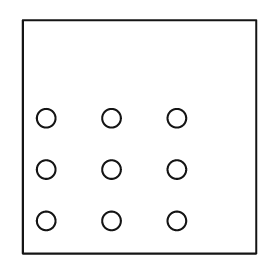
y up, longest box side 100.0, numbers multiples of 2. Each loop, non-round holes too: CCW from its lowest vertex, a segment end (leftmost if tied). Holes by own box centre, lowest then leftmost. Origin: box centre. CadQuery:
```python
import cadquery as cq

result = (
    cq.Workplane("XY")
    .moveTo(-50.0, -50.0)
    .lineTo(50.0, -50.0)
    .lineTo(50.0, 50.0)
    .lineTo(-50.0, 50.0)
    .close()
    .moveTo(-40.0, -36.0)
    .circle(4.0)
    .moveTo(-12.0, -36.0)
    .circle(4.0)
    .moveTo(16.0, -36.0)
    .circle(4.0)
    .moveTo(-40.0, -14.0)
    .circle(4.0)
    .moveTo(-12.0, -14.0)
    .circle(4.0)
    .moveTo(16.0, -14.0)
    .circle(4.0)
    .moveTo(-40.0, 8.0)
    .circle(4.0)
    .moveTo(-12.0, 8.0)
    .circle(4.0)
    .moveTo(16.0, 8.0)
    .circle(4.0)
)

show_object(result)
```